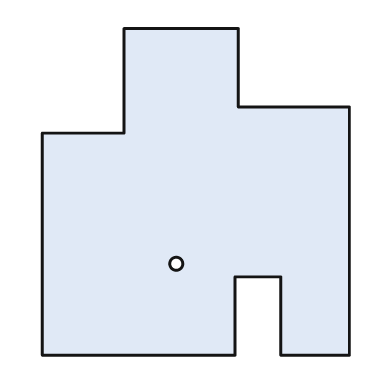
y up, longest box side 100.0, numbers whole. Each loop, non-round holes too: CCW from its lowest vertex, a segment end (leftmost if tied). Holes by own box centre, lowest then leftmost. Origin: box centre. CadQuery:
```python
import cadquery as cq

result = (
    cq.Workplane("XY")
    .moveTo(-47.0, -50.0)
    .lineTo(12.0, -50.0)
    .lineTo(12.0, -26.0)
    .lineTo(26.0, -26.0)
    .lineTo(26.0, -50.0)
    .lineTo(47.0, -50.0)
    .lineTo(47.0, 26.0)
    .lineTo(13.0, 26.0)
    .lineTo(13.0, 50.0)
    .lineTo(-22.0, 50.0)
    .lineTo(-22.0, 18.0)
    .lineTo(-47.0, 18.0)
    .close()
    .moveTo(-6.0, -22.0)
    .circle(2.0)
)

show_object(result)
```